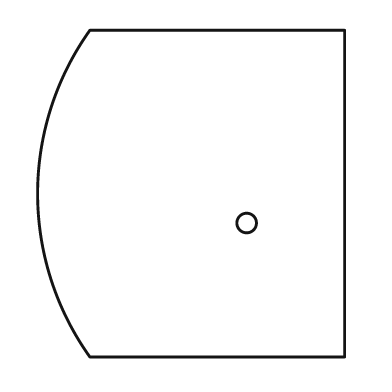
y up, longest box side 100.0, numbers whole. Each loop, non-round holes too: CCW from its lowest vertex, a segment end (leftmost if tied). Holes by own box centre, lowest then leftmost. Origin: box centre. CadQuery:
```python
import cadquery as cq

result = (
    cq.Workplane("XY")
    .moveTo(-31.0, -50.0)
    .lineTo(47.0, -50.0)
    .lineTo(47.0, 50.0)
    .lineTo(-31.0, 50.0)
    .threePointArc((-47.0, 0.0), (-31.0, -50.0))
    .close()
    .moveTo(17.0, -9.0)
    .circle(3.0)
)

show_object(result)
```